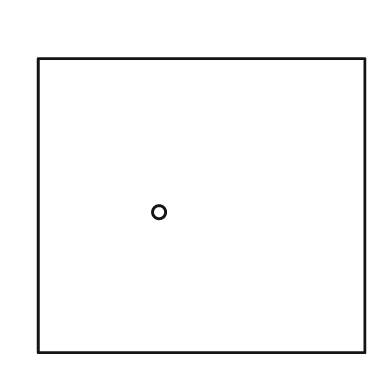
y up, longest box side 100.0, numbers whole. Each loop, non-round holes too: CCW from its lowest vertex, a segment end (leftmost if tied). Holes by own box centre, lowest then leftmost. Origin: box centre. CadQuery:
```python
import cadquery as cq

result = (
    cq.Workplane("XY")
    .moveTo(-50.0, -45.0)
    .lineTo(50.0, -45.0)
    .lineTo(50.0, 45.0)
    .lineTo(-50.0, 45.0)
    .close()
    .moveTo(-13.0, -2.0)
    .circle(2.0)
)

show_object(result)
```